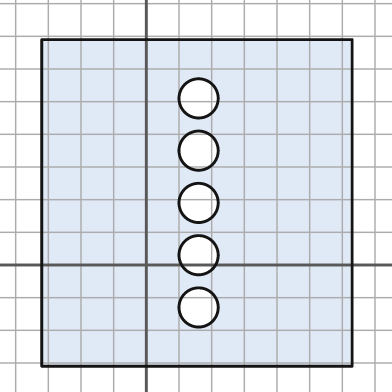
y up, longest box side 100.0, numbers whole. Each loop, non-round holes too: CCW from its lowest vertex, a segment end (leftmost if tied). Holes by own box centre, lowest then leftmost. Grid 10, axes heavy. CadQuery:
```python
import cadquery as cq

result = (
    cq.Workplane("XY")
    .moveTo(-32.0, -31.0)
    .lineTo(63.0, -31.0)
    .lineTo(63.0, 69.0)
    .lineTo(-32.0, 69.0)
    .close()
    .moveTo(16.0, -13.0)
    .circle(6.0)
    .moveTo(16.0, 3.0)
    .circle(6.0)
    .moveTo(16.0, 19.0)
    .circle(6.0)
    .moveTo(16.0, 35.0)
    .circle(6.0)
    .moveTo(16.0, 51.0)
    .circle(6.0)
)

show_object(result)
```